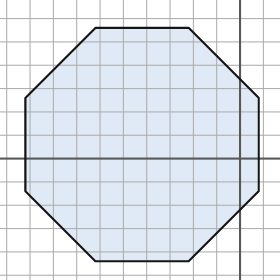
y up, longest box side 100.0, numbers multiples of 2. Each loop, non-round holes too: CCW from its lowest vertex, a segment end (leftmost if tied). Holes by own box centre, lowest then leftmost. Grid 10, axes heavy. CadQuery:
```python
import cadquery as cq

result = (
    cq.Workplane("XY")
    .moveTo(-62.0, -44.0)
    .lineTo(-22.0, -44.0)
    .lineTo(8.0, -14.0)
    .lineTo(8.0, 26.0)
    .lineTo(-22.0, 56.0)
    .lineTo(-62.0, 56.0)
    .lineTo(-92.0, 26.0)
    .lineTo(-92.0, -14.0)
    .close()
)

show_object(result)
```